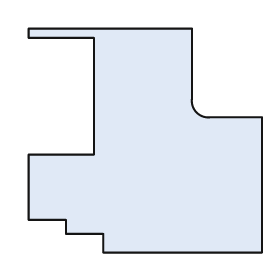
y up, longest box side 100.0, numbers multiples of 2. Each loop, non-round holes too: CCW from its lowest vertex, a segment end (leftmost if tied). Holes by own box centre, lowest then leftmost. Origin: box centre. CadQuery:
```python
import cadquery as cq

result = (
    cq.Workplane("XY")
    .moveTo(-18.0, -48.0)
    .lineTo(50.0, -48.0)
    .lineTo(50.0, 10.0)
    .lineTo(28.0, 10.0)
    .threePointArc((22.0, 12.0), (20.0, 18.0))
    .lineTo(20.0, 48.0)
    .lineTo(-50.0, 48.0)
    .lineTo(-50.0, 44.0)
    .lineTo(-22.0, 44.0)
    .lineTo(-22.0, -6.0)
    .lineTo(-50.0, -6.0)
    .lineTo(-50.0, -34.0)
    .lineTo(-34.0, -34.0)
    .lineTo(-34.0, -40.0)
    .lineTo(-18.0, -40.0)
    .close()
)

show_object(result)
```